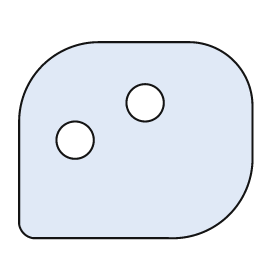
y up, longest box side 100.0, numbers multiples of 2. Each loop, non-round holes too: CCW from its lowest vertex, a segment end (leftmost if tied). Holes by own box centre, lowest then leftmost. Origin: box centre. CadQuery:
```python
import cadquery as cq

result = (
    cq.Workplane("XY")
    .moveTo(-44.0, -42.0)
    .lineTo(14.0, -42.0)
    .threePointArc((40.0, -32.0), (50.0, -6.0))
    .lineTo(50.0, 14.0)
    .threePointArc((42.0, 34.0), (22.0, 42.0))
    .lineTo(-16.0, 42.0)
    .threePointArc((-40.0, 32.0), (-50.0, 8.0))
    .lineTo(-50.0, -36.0)
    .threePointArc((-48.0, -40.0), (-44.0, -42.0))
    .close()
    .moveTo(-26.0, 0.0)
    .circle(8.0)
    .moveTo(4.0, 16.0)
    .circle(8.0)
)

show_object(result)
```